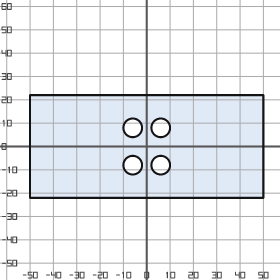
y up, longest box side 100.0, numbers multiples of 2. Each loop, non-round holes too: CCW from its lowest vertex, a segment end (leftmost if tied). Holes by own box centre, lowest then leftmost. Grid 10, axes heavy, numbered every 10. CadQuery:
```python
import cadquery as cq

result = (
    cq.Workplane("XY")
    .moveTo(-50.0, -22.0)
    .lineTo(50.0, -22.0)
    .lineTo(50.0, 22.0)
    .lineTo(-50.0, 22.0)
    .close()
    .moveTo(-6.0, -8.0)
    .circle(4.0)
    .moveTo(6.0, -8.0)
    .circle(4.0)
    .moveTo(-6.0, 8.0)
    .circle(4.0)
    .moveTo(6.0, 8.0)
    .circle(4.0)
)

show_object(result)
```